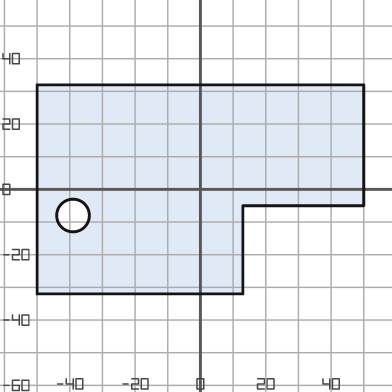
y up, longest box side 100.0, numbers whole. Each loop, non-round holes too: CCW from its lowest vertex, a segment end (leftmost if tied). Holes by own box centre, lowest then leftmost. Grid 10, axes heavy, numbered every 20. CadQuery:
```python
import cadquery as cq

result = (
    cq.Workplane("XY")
    .moveTo(-50.0, -32.0)
    .lineTo(13.0, -32.0)
    .lineTo(13.0, -5.0)
    .lineTo(50.0, -5.0)
    .lineTo(50.0, 32.0)
    .lineTo(-50.0, 32.0)
    .close()
    .moveTo(-39.0, -8.0)
    .circle(5.0)
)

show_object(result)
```